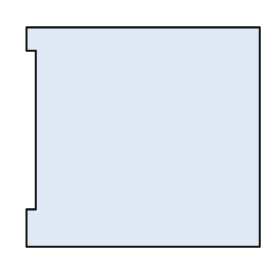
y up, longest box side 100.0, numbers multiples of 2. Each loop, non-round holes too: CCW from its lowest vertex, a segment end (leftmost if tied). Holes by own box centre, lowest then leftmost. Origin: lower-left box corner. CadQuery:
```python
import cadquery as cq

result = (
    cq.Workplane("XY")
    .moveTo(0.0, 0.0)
    .lineTo(100.0, 0.0)
    .lineTo(100.0, 94.0)
    .lineTo(0.0, 94.0)
    .lineTo(0.0, 84.0)
    .lineTo(4.0, 84.0)
    .lineTo(4.0, 16.0)
    .lineTo(0.0, 16.0)
    .close()
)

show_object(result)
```